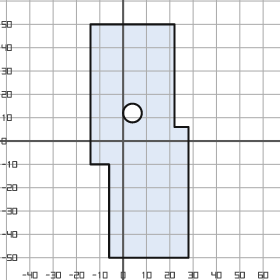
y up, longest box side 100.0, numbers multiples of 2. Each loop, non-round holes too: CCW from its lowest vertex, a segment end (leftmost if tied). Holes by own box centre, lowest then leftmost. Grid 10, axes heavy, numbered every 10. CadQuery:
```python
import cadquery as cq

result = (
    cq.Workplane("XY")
    .moveTo(-6.0, -50.0)
    .lineTo(28.0, -50.0)
    .lineTo(28.0, 6.0)
    .lineTo(22.0, 6.0)
    .lineTo(22.0, 50.0)
    .lineTo(-14.0, 50.0)
    .lineTo(-14.0, -10.0)
    .lineTo(-6.0, -10.0)
    .close()
    .moveTo(4.0, 12.0)
    .circle(4.0)
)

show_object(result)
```